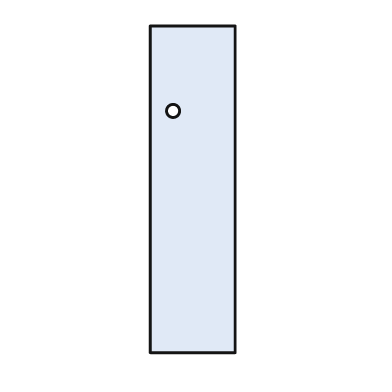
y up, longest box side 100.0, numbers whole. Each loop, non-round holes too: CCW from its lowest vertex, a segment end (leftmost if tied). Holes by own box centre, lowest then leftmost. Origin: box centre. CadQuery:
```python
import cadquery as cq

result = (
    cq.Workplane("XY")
    .moveTo(-13.0, -50.0)
    .lineTo(13.0, -50.0)
    .lineTo(13.0, 50.0)
    .lineTo(-13.0, 50.0)
    .close()
    .moveTo(-6.0, 24.0)
    .circle(2.0)
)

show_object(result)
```